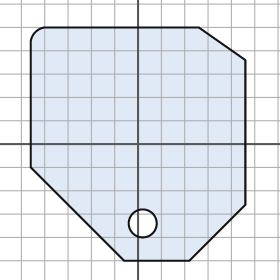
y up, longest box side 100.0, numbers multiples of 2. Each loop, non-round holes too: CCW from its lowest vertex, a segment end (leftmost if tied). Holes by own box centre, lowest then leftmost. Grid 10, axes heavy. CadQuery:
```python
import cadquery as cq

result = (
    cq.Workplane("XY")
    .moveTo(-6.0, -50.0)
    .lineTo(22.0, -50.0)
    .lineTo(46.0, -26.0)
    .lineTo(46.0, 36.0)
    .lineTo(26.0, 50.0)
    .lineTo(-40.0, 50.0)
    .threePointArc((-44.0, 48.0), (-46.0, 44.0))
    .lineTo(-46.0, -10.0)
    .close()
    .moveTo(2.0, -34.0)
    .circle(6.0)
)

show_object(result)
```